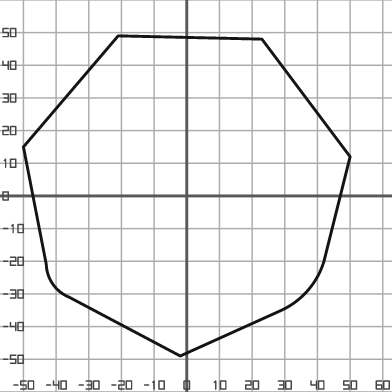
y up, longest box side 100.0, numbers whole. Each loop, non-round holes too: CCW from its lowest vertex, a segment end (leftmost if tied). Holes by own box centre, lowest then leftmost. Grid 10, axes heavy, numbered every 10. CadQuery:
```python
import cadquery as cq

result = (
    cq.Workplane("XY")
    .moveTo(-2.0, -49.0)
    .lineTo(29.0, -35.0)
    .threePointArc((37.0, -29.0), (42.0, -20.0))
    .lineTo(50.0, 12.0)
    .lineTo(23.0, 48.0)
    .lineTo(-21.0, 49.0)
    .lineTo(-50.0, 15.0)
    .lineTo(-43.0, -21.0)
    .threePointArc((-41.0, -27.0), (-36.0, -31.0))
    .close()
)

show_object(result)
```